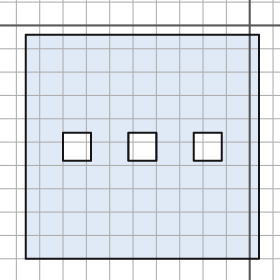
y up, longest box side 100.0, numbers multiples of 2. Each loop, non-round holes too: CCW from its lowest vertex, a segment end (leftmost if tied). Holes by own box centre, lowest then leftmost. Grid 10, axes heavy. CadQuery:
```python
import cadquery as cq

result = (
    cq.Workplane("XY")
    .moveTo(-96.0, -100.0)
    .lineTo(4.0, -100.0)
    .lineTo(4.0, -4.0)
    .lineTo(-96.0, -4.0)
    .close()
    .moveTo(-80.0, -58.0)
    .lineTo(-68.0, -58.0)
    .lineTo(-68.0, -46.0)
    .lineTo(-80.0, -46.0)
    .close()
    .moveTo(-52.0, -58.0)
    .lineTo(-40.0, -58.0)
    .lineTo(-40.0, -46.0)
    .lineTo(-52.0, -46.0)
    .close()
    .moveTo(-24.0, -58.0)
    .lineTo(-12.0, -58.0)
    .lineTo(-12.0, -46.0)
    .lineTo(-24.0, -46.0)
    .close()
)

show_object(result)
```